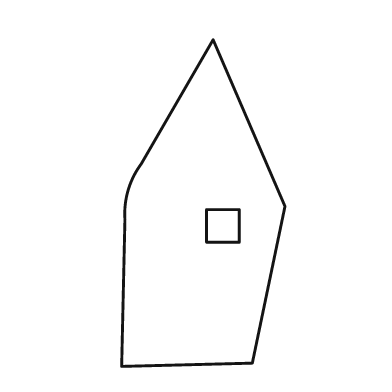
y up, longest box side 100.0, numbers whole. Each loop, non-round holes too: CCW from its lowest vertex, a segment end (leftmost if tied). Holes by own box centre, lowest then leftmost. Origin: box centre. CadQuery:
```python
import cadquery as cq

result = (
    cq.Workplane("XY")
    .moveTo(-25.0, -50.0)
    .lineTo(15.0, -49.0)
    .lineTo(25.0, -1.0)
    .lineTo(3.0, 50.0)
    .lineTo(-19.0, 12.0)
    .threePointArc((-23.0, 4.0), (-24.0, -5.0))
    .close()
    .moveTo(1.0, -12.0)
    .lineTo(11.0, -12.0)
    .lineTo(11.0, -2.0)
    .lineTo(1.0, -2.0)
    .close()
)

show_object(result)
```